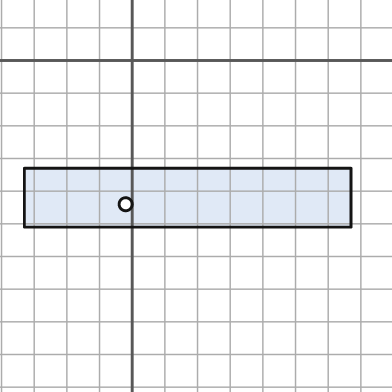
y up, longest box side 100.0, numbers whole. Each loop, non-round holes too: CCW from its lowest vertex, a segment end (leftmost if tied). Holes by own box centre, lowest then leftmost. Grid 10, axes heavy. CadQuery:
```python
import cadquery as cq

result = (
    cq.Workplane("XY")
    .moveTo(-33.0, -51.0)
    .lineTo(67.0, -51.0)
    .lineTo(67.0, -33.0)
    .lineTo(-33.0, -33.0)
    .close()
    .moveTo(-2.0, -44.0)
    .circle(2.0)
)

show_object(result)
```